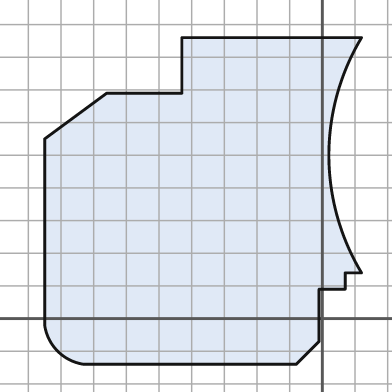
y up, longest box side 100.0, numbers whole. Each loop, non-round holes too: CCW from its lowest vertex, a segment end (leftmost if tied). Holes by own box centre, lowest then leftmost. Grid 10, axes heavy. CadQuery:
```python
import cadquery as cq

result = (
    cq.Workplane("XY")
    .moveTo(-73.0, -14.0)
    .lineTo(-8.0, -14.0)
    .lineTo(-1.0, -7.0)
    .lineTo(-1.0, 9.0)
    .lineTo(7.0, 9.0)
    .lineTo(7.0, 14.0)
    .lineTo(12.0, 14.0)
    .threePointArc((2.0, 50.0), (12.0, 86.0))
    .lineTo(-43.0, 86.0)
    .lineTo(-43.0, 69.0)
    .lineTo(-66.0, 69.0)
    .lineTo(-85.0, 55.0)
    .lineTo(-85.0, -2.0)
    .threePointArc((-81.0, -10.0), (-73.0, -14.0))
    .close()
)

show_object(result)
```